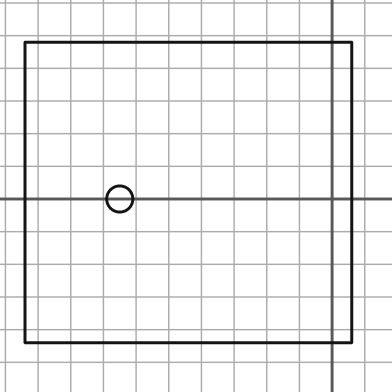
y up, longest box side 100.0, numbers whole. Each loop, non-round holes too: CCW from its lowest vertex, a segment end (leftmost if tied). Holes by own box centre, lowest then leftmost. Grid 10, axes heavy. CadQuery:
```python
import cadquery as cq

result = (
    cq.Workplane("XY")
    .moveTo(-94.0, -44.0)
    .lineTo(6.0, -44.0)
    .lineTo(6.0, 48.0)
    .lineTo(-94.0, 48.0)
    .close()
    .moveTo(-65.0, 0.0)
    .circle(4.0)
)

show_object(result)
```